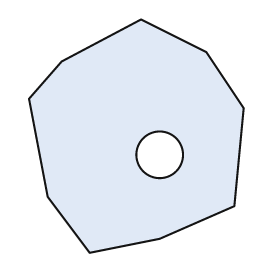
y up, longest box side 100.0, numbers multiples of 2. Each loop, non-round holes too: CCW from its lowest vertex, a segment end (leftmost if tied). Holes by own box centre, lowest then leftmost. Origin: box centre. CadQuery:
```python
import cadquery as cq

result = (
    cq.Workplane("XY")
    .moveTo(-20.0, -50.0)
    .lineTo(10.0, -44.0)
    .lineTo(42.0, -30.0)
    .lineTo(46.0, 12.0)
    .lineTo(30.0, 36.0)
    .lineTo(2.0, 50.0)
    .lineTo(-32.0, 32.0)
    .lineTo(-46.0, 16.0)
    .lineTo(-38.0, -26.0)
    .close()
    .moveTo(10.0, -8.0)
    .circle(10.0)
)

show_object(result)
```